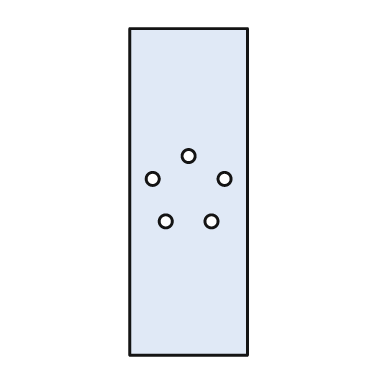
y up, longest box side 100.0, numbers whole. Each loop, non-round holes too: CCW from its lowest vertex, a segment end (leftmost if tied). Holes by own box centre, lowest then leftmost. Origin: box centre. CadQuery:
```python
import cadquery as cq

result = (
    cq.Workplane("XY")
    .moveTo(-18.0, -50.0)
    .lineTo(18.0, -50.0)
    .lineTo(18.0, 50.0)
    .lineTo(-18.0, 50.0)
    .close()
    .moveTo(-7.0, -9.0)
    .circle(2.0)
    .moveTo(7.0, -9.0)
    .circle(2.0)
    .moveTo(-11.0, 4.0)
    .circle(2.0)
    .moveTo(11.0, 4.0)
    .circle(2.0)
    .moveTo(0.0, 11.0)
    .circle(2.0)
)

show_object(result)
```